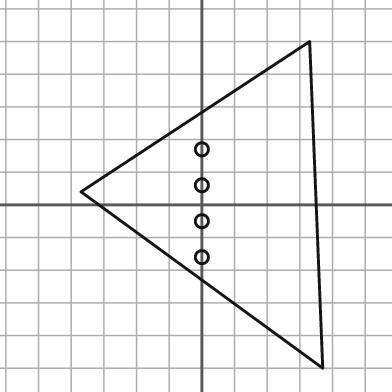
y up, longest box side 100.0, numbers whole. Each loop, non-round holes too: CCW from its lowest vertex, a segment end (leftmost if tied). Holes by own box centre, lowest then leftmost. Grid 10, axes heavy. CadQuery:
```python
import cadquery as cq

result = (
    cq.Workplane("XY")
    .moveTo(37.0, -50.0)
    .lineTo(33.0, 50.0)
    .lineTo(-37.0, 4.0)
    .close()
    .moveTo(0.0, -16.0)
    .circle(2.0)
    .moveTo(0.0, -5.0)
    .circle(2.0)
    .moveTo(0.0, 6.0)
    .circle(2.0)
    .moveTo(0.0, 17.0)
    .circle(2.0)
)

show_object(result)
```